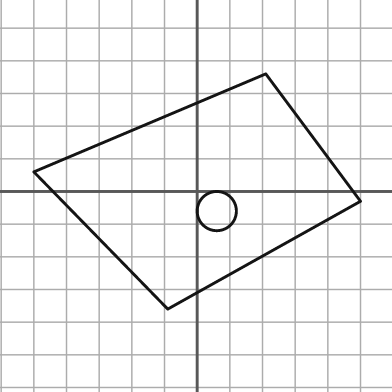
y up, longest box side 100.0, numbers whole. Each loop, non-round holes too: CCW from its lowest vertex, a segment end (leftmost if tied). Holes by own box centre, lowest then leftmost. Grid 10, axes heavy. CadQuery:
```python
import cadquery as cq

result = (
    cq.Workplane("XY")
    .moveTo(-9.0, -36.0)
    .lineTo(50.0, -3.0)
    .lineTo(21.0, 36.0)
    .lineTo(-50.0, 6.0)
    .close()
    .moveTo(6.0, -6.0)
    .circle(6.0)
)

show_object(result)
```